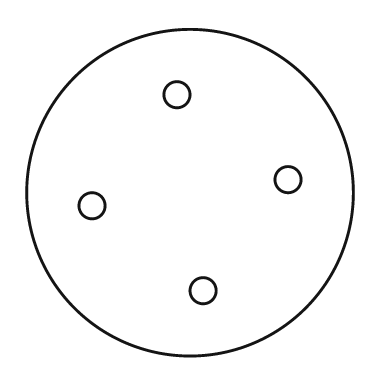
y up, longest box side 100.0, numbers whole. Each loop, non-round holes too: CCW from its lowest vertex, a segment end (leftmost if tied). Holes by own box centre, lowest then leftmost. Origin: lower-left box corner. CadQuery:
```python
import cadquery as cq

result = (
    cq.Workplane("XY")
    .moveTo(50.0, 50.0)
    .circle(50.0)
    .moveTo(54.0, 20.0)
    .circle(4.0)
    .moveTo(20.0, 46.0)
    .circle(4.0)
    .moveTo(80.0, 54.0)
    .circle(4.0)
    .moveTo(46.0, 80.0)
    .circle(4.0)
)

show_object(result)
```